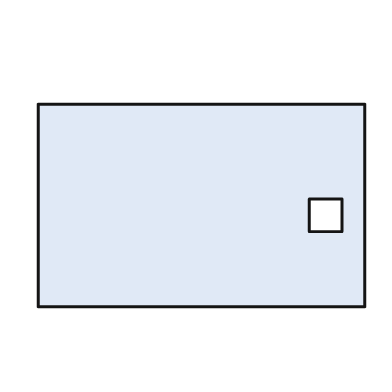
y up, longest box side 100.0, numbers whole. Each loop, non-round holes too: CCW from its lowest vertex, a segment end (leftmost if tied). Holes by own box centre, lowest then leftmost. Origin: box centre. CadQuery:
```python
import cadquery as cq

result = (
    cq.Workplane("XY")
    .moveTo(-50.0, -31.0)
    .lineTo(50.0, -31.0)
    .lineTo(50.0, 31.0)
    .lineTo(-50.0, 31.0)
    .close()
    .moveTo(33.0, -8.0)
    .lineTo(43.0, -8.0)
    .lineTo(43.0, 2.0)
    .lineTo(33.0, 2.0)
    .close()
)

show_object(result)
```